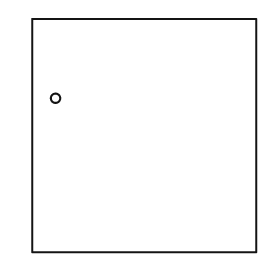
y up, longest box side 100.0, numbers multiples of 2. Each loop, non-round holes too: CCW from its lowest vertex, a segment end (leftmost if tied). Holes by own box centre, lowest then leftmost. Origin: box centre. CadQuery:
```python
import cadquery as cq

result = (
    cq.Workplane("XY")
    .moveTo(-48.0, -50.0)
    .lineTo(48.0, -50.0)
    .lineTo(48.0, 50.0)
    .lineTo(-48.0, 50.0)
    .close()
    .moveTo(-38.0, 16.0)
    .circle(2.0)
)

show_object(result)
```